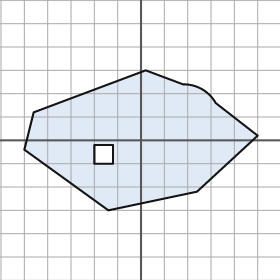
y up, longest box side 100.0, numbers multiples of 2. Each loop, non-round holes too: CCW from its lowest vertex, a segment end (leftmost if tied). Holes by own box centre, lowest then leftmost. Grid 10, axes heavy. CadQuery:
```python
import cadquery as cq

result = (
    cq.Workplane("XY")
    .moveTo(-14.0, -30.0)
    .lineTo(24.0, -22.0)
    .lineTo(50.0, 2.0)
    .lineTo(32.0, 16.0)
    .threePointArc((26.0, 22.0), (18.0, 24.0))
    .lineTo(2.0, 30.0)
    .lineTo(-46.0, 12.0)
    .lineTo(-50.0, -4.0)
    .close()
    .moveTo(-20.0, -10.0)
    .lineTo(-12.0, -10.0)
    .lineTo(-12.0, -2.0)
    .lineTo(-20.0, -2.0)
    .close()
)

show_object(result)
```